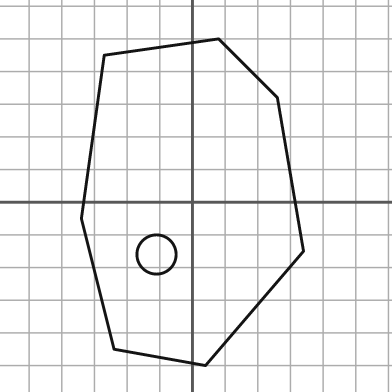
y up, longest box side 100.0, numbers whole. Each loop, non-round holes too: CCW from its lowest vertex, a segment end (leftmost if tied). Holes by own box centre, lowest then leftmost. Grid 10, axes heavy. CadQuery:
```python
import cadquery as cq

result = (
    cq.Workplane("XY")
    .moveTo(4.0, -50.0)
    .lineTo(34.0, -15.0)
    .lineTo(26.0, 32.0)
    .lineTo(8.0, 50.0)
    .lineTo(-27.0, 45.0)
    .lineTo(-34.0, -5.0)
    .lineTo(-24.0, -45.0)
    .close()
    .moveTo(-11.0, -16.0)
    .circle(6.0)
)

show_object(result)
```